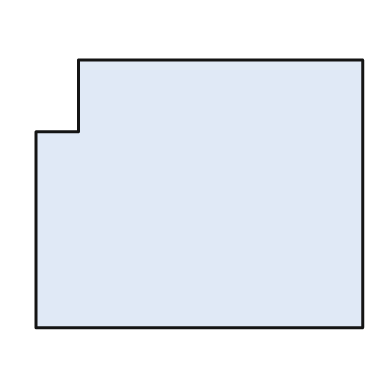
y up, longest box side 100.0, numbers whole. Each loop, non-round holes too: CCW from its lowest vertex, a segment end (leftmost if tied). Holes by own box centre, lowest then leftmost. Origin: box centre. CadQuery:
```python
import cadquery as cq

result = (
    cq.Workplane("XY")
    .moveTo(-50.0, -41.0)
    .lineTo(50.0, -41.0)
    .lineTo(50.0, 41.0)
    .lineTo(-37.0, 41.0)
    .lineTo(-37.0, 19.0)
    .lineTo(-50.0, 19.0)
    .close()
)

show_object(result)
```